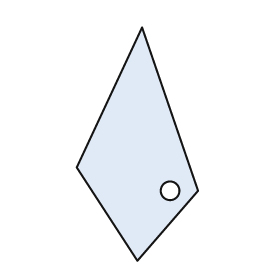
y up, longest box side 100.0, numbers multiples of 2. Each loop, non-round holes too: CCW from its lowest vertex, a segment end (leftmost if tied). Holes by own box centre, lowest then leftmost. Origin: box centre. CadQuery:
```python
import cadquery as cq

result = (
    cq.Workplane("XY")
    .moveTo(0.0, -50.0)
    .lineTo(26.0, -20.0)
    .lineTo(2.0, 50.0)
    .lineTo(-26.0, -10.0)
    .close()
    .moveTo(14.0, -20.0)
    .circle(4.0)
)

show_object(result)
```